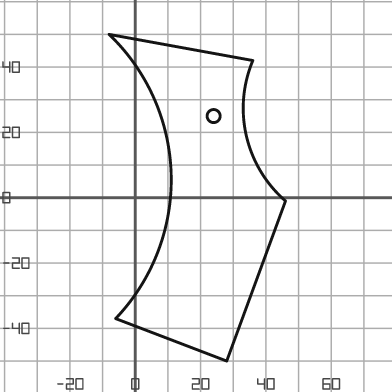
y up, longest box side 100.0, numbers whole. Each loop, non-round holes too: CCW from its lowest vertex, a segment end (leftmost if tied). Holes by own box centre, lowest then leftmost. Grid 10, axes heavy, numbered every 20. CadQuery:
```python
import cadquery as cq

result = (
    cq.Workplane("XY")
    .moveTo(28.0, -50.0)
    .lineTo(46.0, -1.0)
    .threePointArc((34.0, 19.0), (36.0, 42.0))
    .lineTo(-8.0, 50.0)
    .threePointArc((11.0, 7.0), (-6.0, -37.0))
    .close()
    .moveTo(24.0, 25.0)
    .circle(2.0)
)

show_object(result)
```